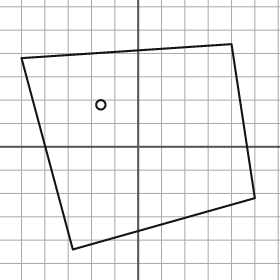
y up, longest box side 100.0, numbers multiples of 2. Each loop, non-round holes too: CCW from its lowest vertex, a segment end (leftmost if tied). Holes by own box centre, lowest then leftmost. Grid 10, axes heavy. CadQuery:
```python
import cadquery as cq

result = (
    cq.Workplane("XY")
    .moveTo(-28.0, -44.0)
    .lineTo(50.0, -22.0)
    .lineTo(40.0, 44.0)
    .lineTo(-50.0, 38.0)
    .close()
    .moveTo(-16.0, 18.0)
    .circle(2.0)
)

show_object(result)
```